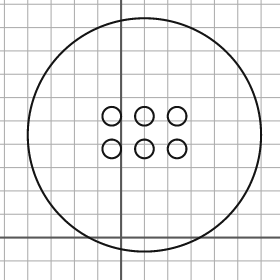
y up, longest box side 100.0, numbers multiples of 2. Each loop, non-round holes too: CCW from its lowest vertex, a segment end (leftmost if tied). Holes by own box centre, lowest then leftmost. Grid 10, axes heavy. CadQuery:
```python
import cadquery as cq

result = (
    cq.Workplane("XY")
    .moveTo(10.0, 44.0)
    .circle(50.0)
    .moveTo(-4.0, 38.0)
    .circle(4.0)
    .moveTo(10.0, 38.0)
    .circle(4.0)
    .moveTo(24.0, 38.0)
    .circle(4.0)
    .moveTo(-4.0, 52.0)
    .circle(4.0)
    .moveTo(10.0, 52.0)
    .circle(4.0)
    .moveTo(24.0, 52.0)
    .circle(4.0)
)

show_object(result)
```